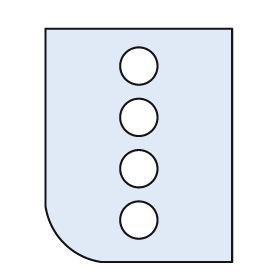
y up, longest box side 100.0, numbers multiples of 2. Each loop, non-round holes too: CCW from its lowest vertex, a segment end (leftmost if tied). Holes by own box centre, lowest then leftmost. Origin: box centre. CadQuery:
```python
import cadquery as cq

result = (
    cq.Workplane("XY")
    .moveTo(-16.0, -50.0)
    .lineTo(40.0, -50.0)
    .lineTo(40.0, 50.0)
    .lineTo(-40.0, 50.0)
    .lineTo(-40.0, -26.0)
    .threePointArc((-32.0, -42.0), (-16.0, -50.0))
    .close()
    .moveTo(0.0, -32.0)
    .circle(8.0)
    .moveTo(0.0, -10.0)
    .circle(8.0)
    .moveTo(0.0, 12.0)
    .circle(8.0)
    .moveTo(0.0, 34.0)
    .circle(8.0)
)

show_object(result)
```